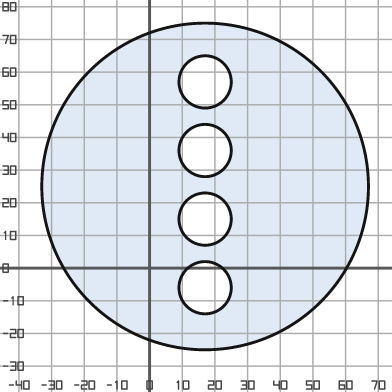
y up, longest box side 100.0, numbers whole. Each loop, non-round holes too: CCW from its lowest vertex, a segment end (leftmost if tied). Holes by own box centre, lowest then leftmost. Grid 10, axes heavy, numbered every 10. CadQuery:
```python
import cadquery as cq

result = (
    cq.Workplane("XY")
    .moveTo(17.0, 25.0)
    .circle(50.0)
    .moveTo(17.0, -6.0)
    .circle(8.0)
    .moveTo(17.0, 15.0)
    .circle(8.0)
    .moveTo(17.0, 36.0)
    .circle(8.0)
    .moveTo(17.0, 57.0)
    .circle(8.0)
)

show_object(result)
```